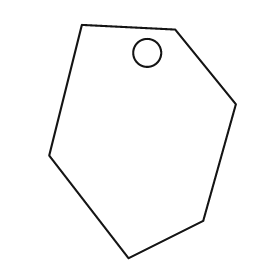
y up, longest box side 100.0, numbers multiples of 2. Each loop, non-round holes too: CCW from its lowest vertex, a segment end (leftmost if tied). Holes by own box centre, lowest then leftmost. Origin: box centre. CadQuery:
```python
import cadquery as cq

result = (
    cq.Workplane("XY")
    .moveTo(-6.0, -50.0)
    .lineTo(26.0, -34.0)
    .lineTo(40.0, 16.0)
    .lineTo(14.0, 48.0)
    .lineTo(-26.0, 50.0)
    .lineTo(-40.0, -6.0)
    .close()
    .moveTo(2.0, 38.0)
    .circle(6.0)
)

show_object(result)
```